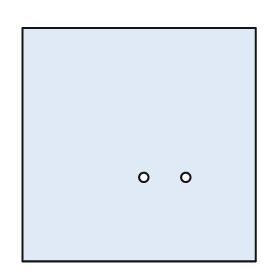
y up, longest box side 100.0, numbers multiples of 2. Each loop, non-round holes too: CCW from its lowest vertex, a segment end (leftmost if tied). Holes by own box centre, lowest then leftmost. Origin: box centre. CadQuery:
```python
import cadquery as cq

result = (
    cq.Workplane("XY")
    .moveTo(-50.0, -50.0)
    .lineTo(50.0, -50.0)
    .lineTo(50.0, 50.0)
    .lineTo(-50.0, 50.0)
    .close()
    .moveTo(2.0, -14.0)
    .circle(2.0)
    .moveTo(20.0, -14.0)
    .circle(2.0)
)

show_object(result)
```